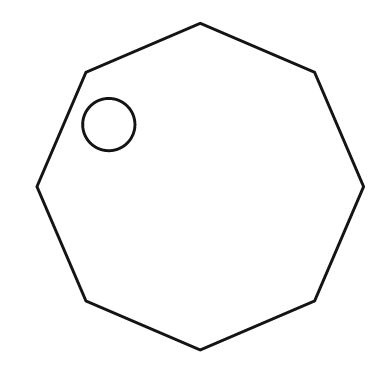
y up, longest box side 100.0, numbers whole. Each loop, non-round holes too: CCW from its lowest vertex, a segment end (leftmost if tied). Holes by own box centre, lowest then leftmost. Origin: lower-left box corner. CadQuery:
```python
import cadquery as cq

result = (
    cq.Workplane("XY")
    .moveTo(50.0, 0.0)
    .lineTo(85.0, 15.0)
    .lineTo(100.0, 50.0)
    .lineTo(85.0, 85.0)
    .lineTo(50.0, 100.0)
    .lineTo(15.0, 85.0)
    .lineTo(0.0, 50.0)
    .lineTo(15.0, 15.0)
    .close()
    .moveTo(22.0, 69.0)
    .circle(8.0)
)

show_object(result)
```